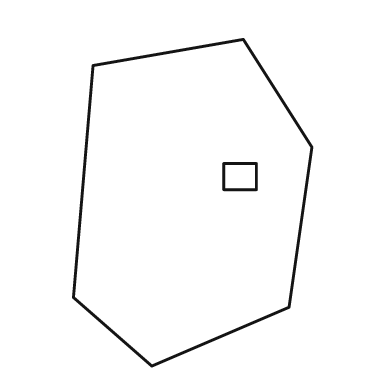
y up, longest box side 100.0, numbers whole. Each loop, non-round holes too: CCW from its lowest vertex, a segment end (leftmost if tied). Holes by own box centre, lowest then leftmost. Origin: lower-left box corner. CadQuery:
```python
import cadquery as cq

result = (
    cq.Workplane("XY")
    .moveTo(24.0, 0.0)
    .lineTo(66.0, 18.0)
    .lineTo(73.0, 67.0)
    .lineTo(52.0, 100.0)
    .lineTo(6.0, 92.0)
    .lineTo(0.0, 21.0)
    .close()
    .moveTo(46.0, 54.0)
    .lineTo(56.0, 54.0)
    .lineTo(56.0, 62.0)
    .lineTo(46.0, 62.0)
    .close()
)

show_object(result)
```